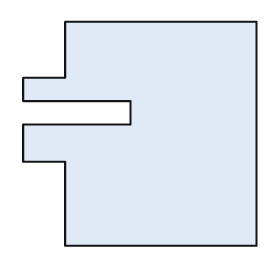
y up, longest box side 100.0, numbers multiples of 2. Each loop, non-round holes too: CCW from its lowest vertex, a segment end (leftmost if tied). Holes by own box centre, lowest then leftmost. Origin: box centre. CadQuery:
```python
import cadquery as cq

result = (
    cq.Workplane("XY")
    .moveTo(-32.0, -48.0)
    .lineTo(50.0, -48.0)
    .lineTo(50.0, 48.0)
    .lineTo(-32.0, 48.0)
    .lineTo(-32.0, 24.0)
    .lineTo(-50.0, 24.0)
    .lineTo(-50.0, 14.0)
    .lineTo(-4.0, 14.0)
    .lineTo(-4.0, 4.0)
    .lineTo(-50.0, 4.0)
    .lineTo(-50.0, -12.0)
    .lineTo(-32.0, -12.0)
    .close()
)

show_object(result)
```